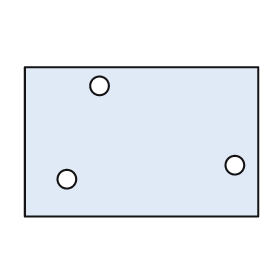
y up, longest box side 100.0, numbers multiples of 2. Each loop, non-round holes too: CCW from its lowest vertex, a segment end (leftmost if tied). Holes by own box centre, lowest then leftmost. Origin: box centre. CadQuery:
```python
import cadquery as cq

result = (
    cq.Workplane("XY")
    .moveTo(-50.0, -32.0)
    .lineTo(50.0, -32.0)
    .lineTo(50.0, 32.0)
    .lineTo(-50.0, 32.0)
    .close()
    .moveTo(-32.0, -16.0)
    .circle(4.0)
    .moveTo(40.0, -10.0)
    .circle(4.0)
    .moveTo(-18.0, 24.0)
    .circle(4.0)
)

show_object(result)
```